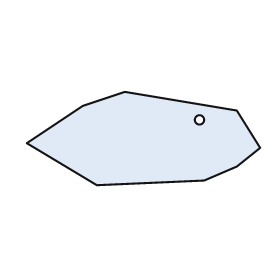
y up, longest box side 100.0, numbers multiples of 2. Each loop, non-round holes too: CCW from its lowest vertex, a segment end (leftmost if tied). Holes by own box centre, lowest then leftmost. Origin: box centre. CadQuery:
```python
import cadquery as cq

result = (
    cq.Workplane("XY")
    .moveTo(-20.0, -20.0)
    .lineTo(26.0, -18.0)
    .lineTo(40.0, -12.0)
    .lineTo(50.0, -4.0)
    .lineTo(40.0, 12.0)
    .lineTo(-8.0, 20.0)
    .lineTo(-26.0, 14.0)
    .lineTo(-50.0, -2.0)
    .close()
    .moveTo(24.0, 8.0)
    .circle(2.0)
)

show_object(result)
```